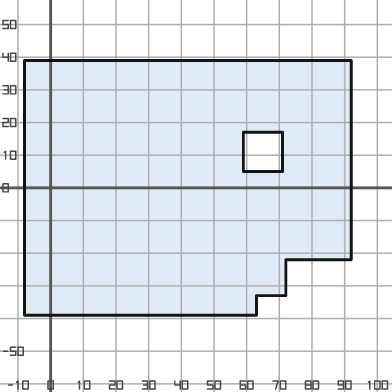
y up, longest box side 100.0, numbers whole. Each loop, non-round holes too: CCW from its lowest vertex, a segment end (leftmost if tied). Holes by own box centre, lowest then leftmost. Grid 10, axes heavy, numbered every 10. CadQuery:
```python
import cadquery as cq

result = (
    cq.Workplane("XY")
    .moveTo(-8.0, -39.0)
    .lineTo(63.0, -39.0)
    .lineTo(63.0, -33.0)
    .lineTo(72.0, -33.0)
    .lineTo(72.0, -22.0)
    .lineTo(92.0, -22.0)
    .lineTo(92.0, 39.0)
    .lineTo(-8.0, 39.0)
    .close()
    .moveTo(59.0, 5.0)
    .lineTo(71.0, 5.0)
    .lineTo(71.0, 17.0)
    .lineTo(59.0, 17.0)
    .close()
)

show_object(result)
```